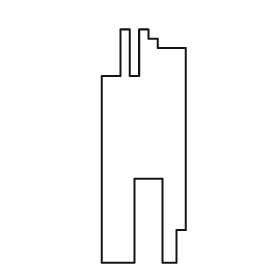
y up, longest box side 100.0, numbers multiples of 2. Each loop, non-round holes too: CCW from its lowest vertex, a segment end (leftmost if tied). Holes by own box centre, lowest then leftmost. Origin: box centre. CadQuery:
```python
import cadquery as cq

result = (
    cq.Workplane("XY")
    .moveTo(-18.0, -50.0)
    .lineTo(-4.0, -50.0)
    .lineTo(-4.0, -14.0)
    .lineTo(8.0, -14.0)
    .lineTo(8.0, -50.0)
    .lineTo(14.0, -50.0)
    .lineTo(14.0, -36.0)
    .lineTo(18.0, -36.0)
    .lineTo(18.0, 42.0)
    .lineTo(6.0, 42.0)
    .lineTo(6.0, 46.0)
    .lineTo(2.0, 46.0)
    .lineTo(2.0, 50.0)
    .lineTo(-2.0, 50.0)
    .lineTo(-2.0, 30.0)
    .lineTo(-6.0, 30.0)
    .lineTo(-6.0, 50.0)
    .lineTo(-10.0, 50.0)
    .lineTo(-10.0, 30.0)
    .lineTo(-18.0, 30.0)
    .close()
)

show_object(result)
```